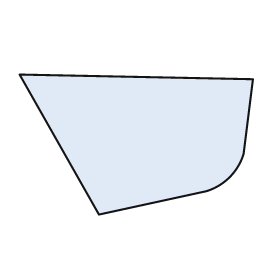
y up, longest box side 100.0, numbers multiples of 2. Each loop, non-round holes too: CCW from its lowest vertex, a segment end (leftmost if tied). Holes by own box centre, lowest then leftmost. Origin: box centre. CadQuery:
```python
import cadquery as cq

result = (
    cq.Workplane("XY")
    .moveTo(-16.0, -30.0)
    .lineTo(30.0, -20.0)
    .threePointArc((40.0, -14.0), (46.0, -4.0))
    .lineTo(50.0, 28.0)
    .lineTo(-50.0, 30.0)
    .close()
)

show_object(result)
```